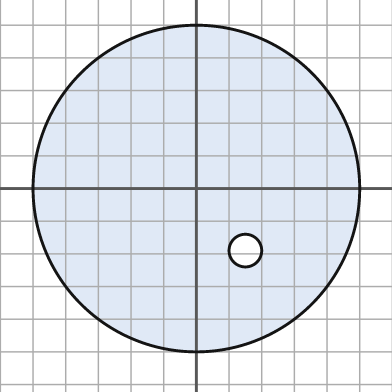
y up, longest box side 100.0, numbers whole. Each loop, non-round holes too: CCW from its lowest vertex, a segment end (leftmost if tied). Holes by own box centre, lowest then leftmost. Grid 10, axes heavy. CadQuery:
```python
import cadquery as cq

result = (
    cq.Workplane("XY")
    .moveTo(0.0, 0.0)
    .circle(50.0)
    .moveTo(15.0, -19.0)
    .circle(5.0)
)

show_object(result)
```